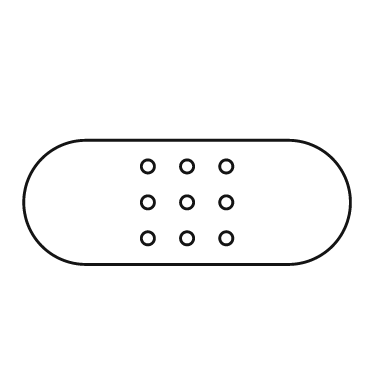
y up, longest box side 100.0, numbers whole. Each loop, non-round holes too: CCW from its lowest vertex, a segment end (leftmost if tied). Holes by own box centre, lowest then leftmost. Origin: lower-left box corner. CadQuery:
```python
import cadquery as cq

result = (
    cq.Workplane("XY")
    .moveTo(19.0, 0.0)
    .lineTo(81.0, 0.0)
    .threePointArc((100.0, 19.0), (81.0, 38.0))
    .lineTo(19.0, 38.0)
    .threePointArc((0.0, 19.0), (19.0, 0.0))
    .close()
    .moveTo(38.0, 8.0)
    .circle(2.0)
    .moveTo(50.0, 8.0)
    .circle(2.0)
    .moveTo(62.0, 8.0)
    .circle(2.0)
    .moveTo(38.0, 19.0)
    .circle(2.0)
    .moveTo(50.0, 19.0)
    .circle(2.0)
    .moveTo(62.0, 19.0)
    .circle(2.0)
    .moveTo(38.0, 30.0)
    .circle(2.0)
    .moveTo(50.0, 30.0)
    .circle(2.0)
    .moveTo(62.0, 30.0)
    .circle(2.0)
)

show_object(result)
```